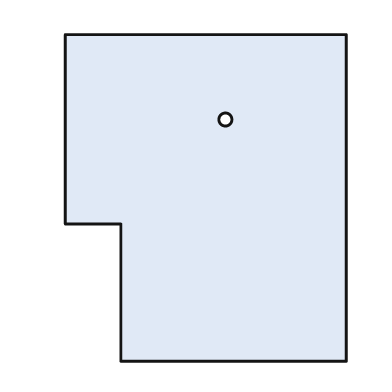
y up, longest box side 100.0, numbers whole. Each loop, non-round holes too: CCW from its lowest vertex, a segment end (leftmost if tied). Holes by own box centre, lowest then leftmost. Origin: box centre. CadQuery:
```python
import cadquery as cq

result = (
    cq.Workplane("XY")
    .moveTo(-26.0, -50.0)
    .lineTo(43.0, -50.0)
    .lineTo(43.0, 50.0)
    .lineTo(-43.0, 50.0)
    .lineTo(-43.0, -8.0)
    .lineTo(-26.0, -8.0)
    .close()
    .moveTo(6.0, 24.0)
    .circle(2.0)
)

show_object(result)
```